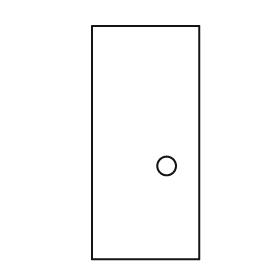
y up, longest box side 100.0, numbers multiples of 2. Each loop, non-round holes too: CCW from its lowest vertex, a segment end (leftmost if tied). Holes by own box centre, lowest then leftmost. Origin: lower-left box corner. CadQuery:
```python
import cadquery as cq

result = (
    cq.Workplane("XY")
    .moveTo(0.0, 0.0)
    .lineTo(46.0, 0.0)
    .lineTo(46.0, 100.0)
    .lineTo(0.0, 100.0)
    .close()
    .moveTo(32.0, 40.0)
    .circle(4.0)
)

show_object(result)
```